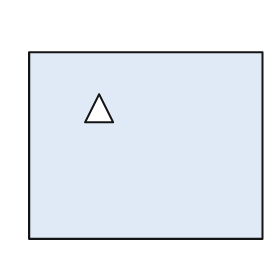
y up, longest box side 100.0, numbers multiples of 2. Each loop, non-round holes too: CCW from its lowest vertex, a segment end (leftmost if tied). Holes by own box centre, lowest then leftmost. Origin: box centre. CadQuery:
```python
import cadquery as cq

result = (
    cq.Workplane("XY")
    .moveTo(-50.0, -40.0)
    .lineTo(50.0, -40.0)
    .lineTo(50.0, 40.0)
    .lineTo(-50.0, 40.0)
    .close()
    .moveTo(-26.0, 10.0)
    .lineTo(-14.0, 10.0)
    .lineTo(-20.0, 22.0)
    .close()
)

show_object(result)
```